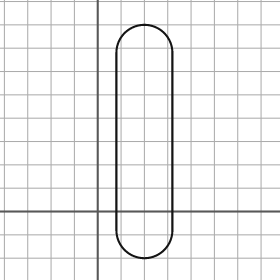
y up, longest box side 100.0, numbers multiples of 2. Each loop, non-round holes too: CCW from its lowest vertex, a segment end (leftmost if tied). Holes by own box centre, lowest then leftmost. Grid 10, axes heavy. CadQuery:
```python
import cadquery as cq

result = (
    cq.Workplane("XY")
    .moveTo(8.0, -8.0)
    .threePointArc((20.0, -20.0), (32.0, -8.0))
    .lineTo(32.0, 68.0)
    .threePointArc((20.0, 80.0), (8.0, 68.0))
    .close()
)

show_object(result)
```